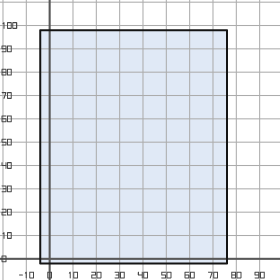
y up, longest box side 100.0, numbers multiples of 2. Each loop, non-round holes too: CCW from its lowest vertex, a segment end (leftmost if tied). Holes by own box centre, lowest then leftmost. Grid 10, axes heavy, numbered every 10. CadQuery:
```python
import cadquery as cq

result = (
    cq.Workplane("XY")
    .moveTo(-4.0, -2.0)
    .lineTo(76.0, -2.0)
    .lineTo(76.0, 98.0)
    .lineTo(-4.0, 98.0)
    .close()
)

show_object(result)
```